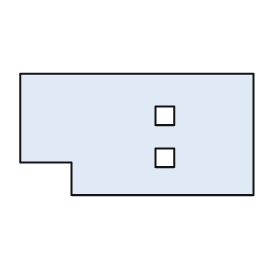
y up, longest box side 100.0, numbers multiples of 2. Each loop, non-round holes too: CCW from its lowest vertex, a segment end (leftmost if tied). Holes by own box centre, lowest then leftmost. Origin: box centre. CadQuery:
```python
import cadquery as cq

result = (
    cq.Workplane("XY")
    .moveTo(-28.0, -26.0)
    .lineTo(50.0, -26.0)
    .lineTo(50.0, 26.0)
    .lineTo(-50.0, 26.0)
    .lineTo(-50.0, -12.0)
    .lineTo(-28.0, -12.0)
    .close()
    .moveTo(8.0, -14.0)
    .lineTo(16.0, -14.0)
    .lineTo(16.0, -6.0)
    .lineTo(8.0, -6.0)
    .close()
    .moveTo(8.0, 4.0)
    .lineTo(16.0, 4.0)
    .lineTo(16.0, 12.0)
    .lineTo(8.0, 12.0)
    .close()
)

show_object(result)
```